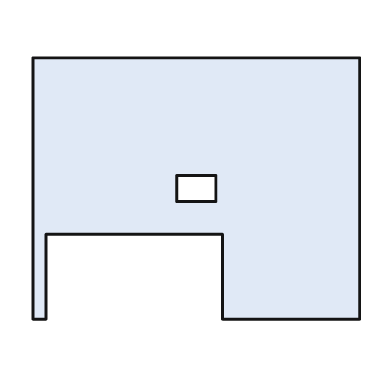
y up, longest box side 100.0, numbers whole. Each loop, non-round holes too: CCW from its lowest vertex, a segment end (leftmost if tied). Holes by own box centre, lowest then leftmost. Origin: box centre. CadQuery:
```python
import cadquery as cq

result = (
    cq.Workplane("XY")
    .moveTo(-50.0, -40.0)
    .lineTo(-46.0, -40.0)
    .lineTo(-46.0, -14.0)
    .lineTo(8.0, -14.0)
    .lineTo(8.0, -40.0)
    .lineTo(50.0, -40.0)
    .lineTo(50.0, 40.0)
    .lineTo(-50.0, 40.0)
    .close()
    .moveTo(-6.0, -4.0)
    .lineTo(6.0, -4.0)
    .lineTo(6.0, 4.0)
    .lineTo(-6.0, 4.0)
    .close()
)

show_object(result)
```